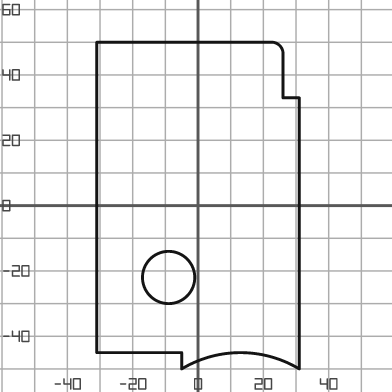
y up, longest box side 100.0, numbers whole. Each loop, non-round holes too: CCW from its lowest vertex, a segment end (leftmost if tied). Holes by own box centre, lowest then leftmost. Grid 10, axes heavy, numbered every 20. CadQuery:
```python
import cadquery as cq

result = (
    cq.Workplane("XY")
    .moveTo(-5.0, -50.0)
    .threePointArc((13.0, -45.0), (31.0, -50.0))
    .lineTo(31.0, 33.0)
    .lineTo(26.0, 33.0)
    .lineTo(26.0, 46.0)
    .threePointArc((25.0, 49.0), (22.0, 50.0))
    .lineTo(-31.0, 50.0)
    .lineTo(-31.0, -45.0)
    .lineTo(-5.0, -45.0)
    .close()
    .moveTo(-9.0, -22.0)
    .circle(8.0)
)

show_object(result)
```